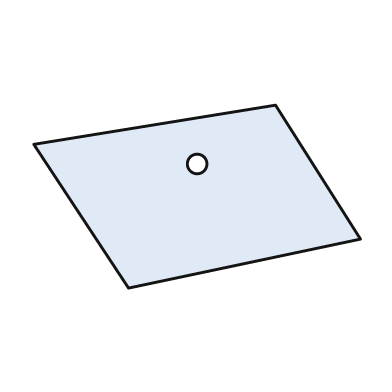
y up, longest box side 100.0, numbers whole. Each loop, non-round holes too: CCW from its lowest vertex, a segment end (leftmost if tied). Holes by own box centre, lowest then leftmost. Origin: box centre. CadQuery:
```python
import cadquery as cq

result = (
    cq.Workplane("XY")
    .moveTo(-21.0, -28.0)
    .lineTo(50.0, -13.0)
    .lineTo(24.0, 28.0)
    .lineTo(-50.0, 16.0)
    .close()
    .moveTo(0.0, 10.0)
    .circle(3.0)
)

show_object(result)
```